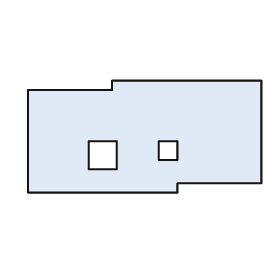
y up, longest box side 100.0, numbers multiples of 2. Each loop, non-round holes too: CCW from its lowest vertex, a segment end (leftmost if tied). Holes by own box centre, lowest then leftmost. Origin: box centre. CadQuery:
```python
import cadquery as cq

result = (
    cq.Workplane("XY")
    .moveTo(-50.0, -24.0)
    .lineTo(14.0, -24.0)
    .lineTo(14.0, -20.0)
    .lineTo(50.0, -20.0)
    .lineTo(50.0, 24.0)
    .lineTo(-14.0, 24.0)
    .lineTo(-14.0, 20.0)
    .lineTo(-50.0, 20.0)
    .close()
    .moveTo(-24.0, -14.0)
    .lineTo(-12.0, -14.0)
    .lineTo(-12.0, -2.0)
    .lineTo(-24.0, -2.0)
    .close()
    .moveTo(6.0, -10.0)
    .lineTo(14.0, -10.0)
    .lineTo(14.0, -2.0)
    .lineTo(6.0, -2.0)
    .close()
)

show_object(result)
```